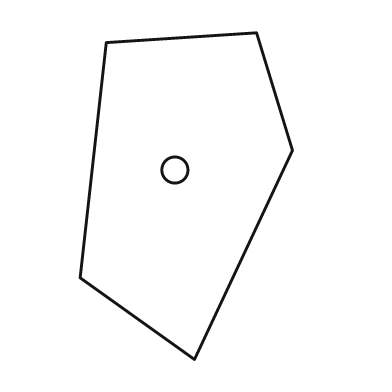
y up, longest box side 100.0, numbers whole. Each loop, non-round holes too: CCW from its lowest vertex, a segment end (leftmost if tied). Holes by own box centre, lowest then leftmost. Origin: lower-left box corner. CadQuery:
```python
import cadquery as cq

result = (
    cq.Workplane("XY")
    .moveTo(35.0, 0.0)
    .lineTo(65.0, 64.0)
    .lineTo(54.0, 100.0)
    .lineTo(8.0, 97.0)
    .lineTo(0.0, 25.0)
    .close()
    .moveTo(29.0, 58.0)
    .circle(4.0)
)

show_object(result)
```